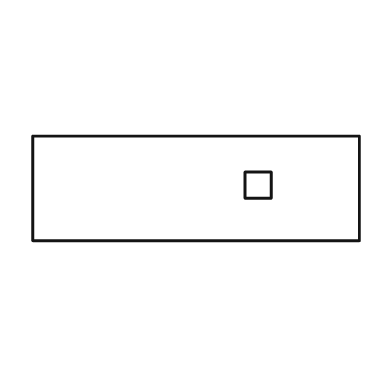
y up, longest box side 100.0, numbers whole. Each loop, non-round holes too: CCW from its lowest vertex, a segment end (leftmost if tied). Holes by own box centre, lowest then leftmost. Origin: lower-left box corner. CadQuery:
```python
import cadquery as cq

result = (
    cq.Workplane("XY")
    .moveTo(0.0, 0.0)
    .lineTo(100.0, 0.0)
    .lineTo(100.0, 32.0)
    .lineTo(0.0, 32.0)
    .close()
    .moveTo(65.0, 13.0)
    .lineTo(73.0, 13.0)
    .lineTo(73.0, 21.0)
    .lineTo(65.0, 21.0)
    .close()
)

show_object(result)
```